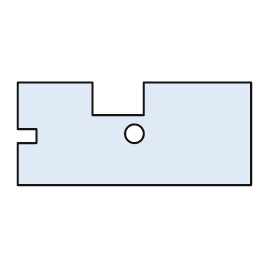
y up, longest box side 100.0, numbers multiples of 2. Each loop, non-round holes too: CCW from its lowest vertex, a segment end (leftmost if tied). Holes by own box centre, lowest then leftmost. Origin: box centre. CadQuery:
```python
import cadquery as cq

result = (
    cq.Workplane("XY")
    .moveTo(-50.0, -22.0)
    .lineTo(50.0, -22.0)
    .lineTo(50.0, 22.0)
    .lineTo(4.0, 22.0)
    .lineTo(4.0, 8.0)
    .lineTo(-18.0, 8.0)
    .lineTo(-18.0, 22.0)
    .lineTo(-50.0, 22.0)
    .lineTo(-50.0, 2.0)
    .lineTo(-42.0, 2.0)
    .lineTo(-42.0, -4.0)
    .lineTo(-50.0, -4.0)
    .close()
    .moveTo(0.0, 0.0)
    .circle(4.0)
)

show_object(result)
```